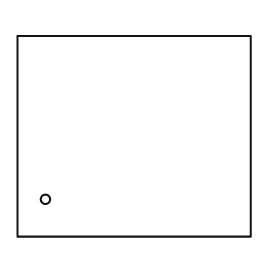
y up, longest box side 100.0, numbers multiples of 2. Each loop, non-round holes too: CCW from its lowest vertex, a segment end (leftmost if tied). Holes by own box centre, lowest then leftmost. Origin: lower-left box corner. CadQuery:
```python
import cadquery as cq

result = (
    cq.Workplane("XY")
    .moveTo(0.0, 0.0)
    .lineTo(100.0, 0.0)
    .lineTo(100.0, 86.0)
    .lineTo(0.0, 86.0)
    .close()
    .moveTo(12.0, 16.0)
    .circle(2.0)
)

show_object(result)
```